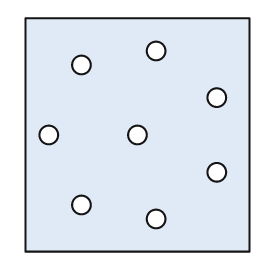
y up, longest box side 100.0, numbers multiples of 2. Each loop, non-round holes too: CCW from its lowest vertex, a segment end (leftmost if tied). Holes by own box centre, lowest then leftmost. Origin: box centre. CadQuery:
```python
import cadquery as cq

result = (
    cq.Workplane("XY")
    .moveTo(-48.0, -50.0)
    .lineTo(48.0, -50.0)
    .lineTo(48.0, 50.0)
    .lineTo(-48.0, 50.0)
    .close()
    .moveTo(8.0, -36.0)
    .circle(4.0)
    .moveTo(-24.0, -30.0)
    .circle(4.0)
    .moveTo(34.0, -16.0)
    .circle(4.0)
    .moveTo(-38.0, 0.0)
    .circle(4.0)
    .moveTo(0.0, 0.0)
    .circle(4.0)
    .moveTo(34.0, 16.0)
    .circle(4.0)
    .moveTo(-24.0, 30.0)
    .circle(4.0)
    .moveTo(8.0, 36.0)
    .circle(4.0)
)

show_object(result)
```